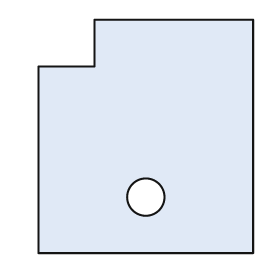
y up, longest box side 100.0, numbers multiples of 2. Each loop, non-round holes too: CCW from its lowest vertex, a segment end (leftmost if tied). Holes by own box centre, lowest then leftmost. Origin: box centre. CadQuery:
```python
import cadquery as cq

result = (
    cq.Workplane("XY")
    .moveTo(-46.0, -50.0)
    .lineTo(46.0, -50.0)
    .lineTo(46.0, 50.0)
    .lineTo(-22.0, 50.0)
    .lineTo(-22.0, 30.0)
    .lineTo(-46.0, 30.0)
    .close()
    .moveTo(0.0, -26.0)
    .circle(8.0)
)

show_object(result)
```